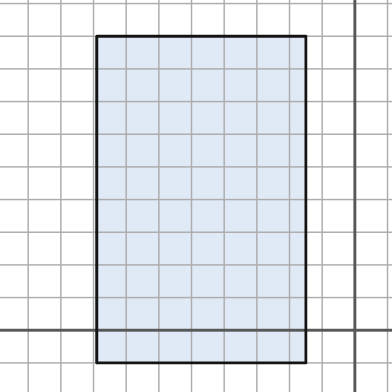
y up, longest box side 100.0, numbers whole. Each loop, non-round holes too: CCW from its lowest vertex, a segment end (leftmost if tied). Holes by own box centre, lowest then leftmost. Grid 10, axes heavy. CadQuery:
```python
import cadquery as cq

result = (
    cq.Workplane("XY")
    .moveTo(-79.0, -10.0)
    .lineTo(-15.0, -10.0)
    .lineTo(-15.0, 90.0)
    .lineTo(-79.0, 90.0)
    .close()
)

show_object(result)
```